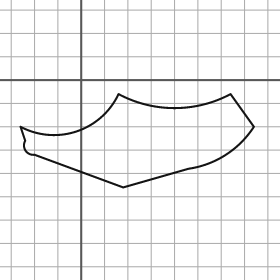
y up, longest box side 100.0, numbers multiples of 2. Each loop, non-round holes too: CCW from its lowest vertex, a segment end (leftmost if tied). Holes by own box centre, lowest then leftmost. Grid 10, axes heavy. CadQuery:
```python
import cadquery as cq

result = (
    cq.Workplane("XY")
    .moveTo(18.0, -46.0)
    .lineTo(46.0, -38.0)
    .threePointArc((62.0, -32.0), (74.0, -20.0))
    .lineTo(64.0, -6.0)
    .threePointArc((40.0, -12.0), (16.0, -6.0))
    .threePointArc((-2.0, -22.0), (-26.0, -20.0))
    .lineTo(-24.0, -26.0)
    .threePointArc((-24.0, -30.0), (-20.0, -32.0))
    .close()
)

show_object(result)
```